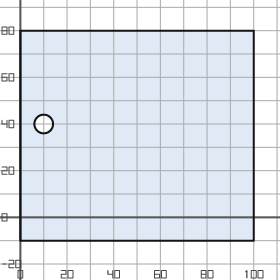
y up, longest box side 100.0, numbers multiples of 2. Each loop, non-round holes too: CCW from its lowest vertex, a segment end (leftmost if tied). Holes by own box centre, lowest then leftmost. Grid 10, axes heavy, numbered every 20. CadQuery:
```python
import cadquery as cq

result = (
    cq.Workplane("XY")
    .moveTo(0.0, -10.0)
    .lineTo(100.0, -10.0)
    .lineTo(100.0, 80.0)
    .lineTo(0.0, 80.0)
    .close()
    .moveTo(10.0, 40.0)
    .circle(4.0)
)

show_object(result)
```